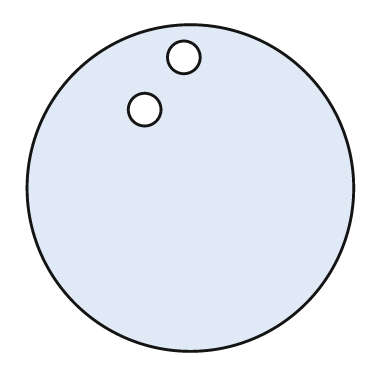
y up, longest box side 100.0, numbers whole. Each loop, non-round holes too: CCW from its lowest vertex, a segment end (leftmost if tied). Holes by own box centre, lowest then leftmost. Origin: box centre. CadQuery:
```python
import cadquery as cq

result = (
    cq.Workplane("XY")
    .moveTo(0.0, 0.0)
    .circle(50.0)
    .moveTo(-14.0, 24.0)
    .circle(5.0)
    .moveTo(-2.0, 40.0)
    .circle(5.0)
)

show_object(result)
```